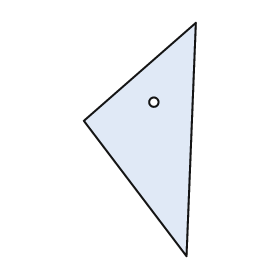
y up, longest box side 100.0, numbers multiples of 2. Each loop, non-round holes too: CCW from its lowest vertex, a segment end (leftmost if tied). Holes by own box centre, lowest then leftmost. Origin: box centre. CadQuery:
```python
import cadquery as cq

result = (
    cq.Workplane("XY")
    .moveTo(20.0, -50.0)
    .lineTo(24.0, 50.0)
    .lineTo(-24.0, 8.0)
    .close()
    .moveTo(6.0, 16.0)
    .circle(2.0)
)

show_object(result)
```